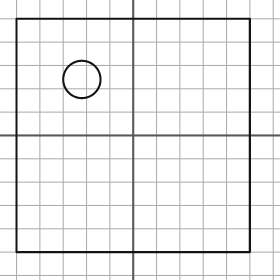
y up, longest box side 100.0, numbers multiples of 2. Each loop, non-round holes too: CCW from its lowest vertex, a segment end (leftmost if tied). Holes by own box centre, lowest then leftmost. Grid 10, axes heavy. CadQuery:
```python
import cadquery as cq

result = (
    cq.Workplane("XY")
    .moveTo(-50.0, -50.0)
    .lineTo(50.0, -50.0)
    .lineTo(50.0, 50.0)
    .lineTo(-50.0, 50.0)
    .close()
    .moveTo(-22.0, 24.0)
    .circle(8.0)
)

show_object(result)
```